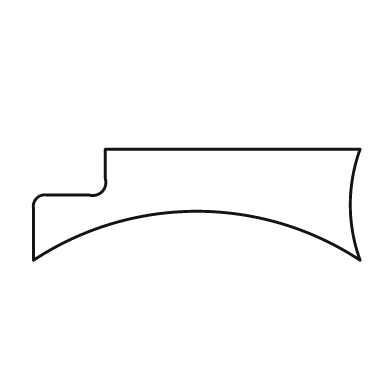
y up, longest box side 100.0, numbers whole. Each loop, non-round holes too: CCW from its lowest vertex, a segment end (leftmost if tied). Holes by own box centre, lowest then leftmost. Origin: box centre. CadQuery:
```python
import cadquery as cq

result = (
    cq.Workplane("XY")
    .moveTo(-50.0, -17.0)
    .threePointArc((0.0, -2.0), (50.0, -17.0))
    .threePointArc((47.0, 0.0), (50.0, 17.0))
    .lineTo(-28.0, 17.0)
    .lineTo(-28.0, 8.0)
    .threePointArc((-29.0, 4.0), (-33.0, 3.0))
    .lineTo(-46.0, 3.0)
    .threePointArc((-49.0, 2.0), (-50.0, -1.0))
    .close()
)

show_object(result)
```